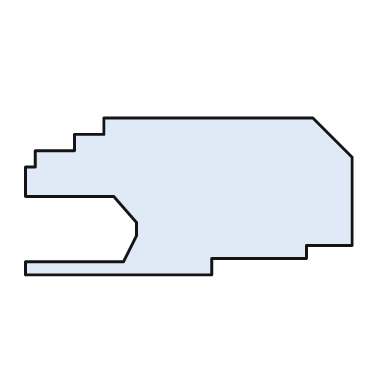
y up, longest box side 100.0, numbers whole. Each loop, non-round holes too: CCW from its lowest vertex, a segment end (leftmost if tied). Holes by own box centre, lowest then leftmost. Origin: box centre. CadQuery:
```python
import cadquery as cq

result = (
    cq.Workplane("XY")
    .moveTo(-50.0, -24.0)
    .lineTo(7.0, -24.0)
    .lineTo(7.0, -19.0)
    .lineTo(36.0, -19.0)
    .lineTo(36.0, -15.0)
    .lineTo(50.0, -15.0)
    .lineTo(50.0, 12.0)
    .lineTo(38.0, 24.0)
    .lineTo(-26.0, 24.0)
    .lineTo(-26.0, 19.0)
    .lineTo(-35.0, 19.0)
    .lineTo(-35.0, 14.0)
    .lineTo(-47.0, 14.0)
    .lineTo(-47.0, 9.0)
    .lineTo(-50.0, 9.0)
    .lineTo(-50.0, 0.0)
    .lineTo(-23.0, 0.0)
    .lineTo(-16.0, -8.0)
    .lineTo(-16.0, -12.0)
    .lineTo(-20.0, -20.0)
    .lineTo(-50.0, -20.0)
    .close()
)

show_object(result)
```